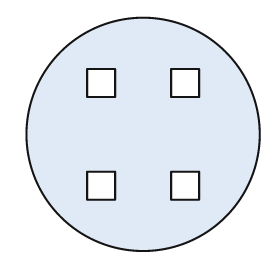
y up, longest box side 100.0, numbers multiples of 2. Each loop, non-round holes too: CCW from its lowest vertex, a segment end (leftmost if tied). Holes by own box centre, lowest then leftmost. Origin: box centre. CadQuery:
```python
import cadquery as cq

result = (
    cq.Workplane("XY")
    .moveTo(0.0, 0.0)
    .circle(50.0)
    .moveTo(-24.0, -28.0)
    .lineTo(-12.0, -28.0)
    .lineTo(-12.0, -16.0)
    .lineTo(-24.0, -16.0)
    .close()
    .moveTo(12.0, -28.0)
    .lineTo(24.0, -28.0)
    .lineTo(24.0, -16.0)
    .lineTo(12.0, -16.0)
    .close()
    .moveTo(-24.0, 16.0)
    .lineTo(-12.0, 16.0)
    .lineTo(-12.0, 28.0)
    .lineTo(-24.0, 28.0)
    .close()
    .moveTo(12.0, 16.0)
    .lineTo(24.0, 16.0)
    .lineTo(24.0, 28.0)
    .lineTo(12.0, 28.0)
    .close()
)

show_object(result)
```